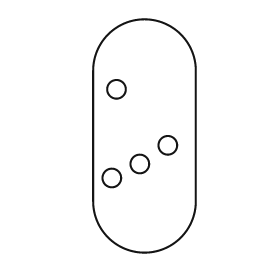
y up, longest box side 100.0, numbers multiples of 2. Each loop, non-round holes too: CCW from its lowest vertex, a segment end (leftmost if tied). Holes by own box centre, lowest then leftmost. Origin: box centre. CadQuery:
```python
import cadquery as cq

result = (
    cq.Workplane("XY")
    .moveTo(-22.0, -28.0)
    .threePointArc((0.0, -50.0), (22.0, -28.0))
    .lineTo(22.0, 28.0)
    .threePointArc((0.0, 50.0), (-22.0, 28.0))
    .close()
    .moveTo(-14.0, -18.0)
    .circle(4.0)
    .moveTo(-2.0, -12.0)
    .circle(4.0)
    .moveTo(10.0, -4.0)
    .circle(4.0)
    .moveTo(-12.0, 20.0)
    .circle(4.0)
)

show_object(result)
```